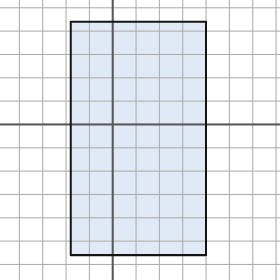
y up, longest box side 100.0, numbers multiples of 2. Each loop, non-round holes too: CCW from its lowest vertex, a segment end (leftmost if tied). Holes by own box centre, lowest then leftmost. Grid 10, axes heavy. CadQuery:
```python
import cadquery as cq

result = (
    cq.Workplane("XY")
    .moveTo(-18.0, -56.0)
    .lineTo(40.0, -56.0)
    .lineTo(40.0, 44.0)
    .lineTo(-18.0, 44.0)
    .close()
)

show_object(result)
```